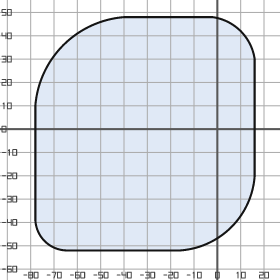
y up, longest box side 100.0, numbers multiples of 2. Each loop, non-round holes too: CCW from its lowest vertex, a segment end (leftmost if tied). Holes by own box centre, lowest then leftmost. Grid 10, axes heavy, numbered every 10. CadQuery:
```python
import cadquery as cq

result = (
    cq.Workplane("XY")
    .moveTo(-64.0, -52.0)
    .lineTo(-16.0, -52.0)
    .threePointArc((6.0, -42.0), (16.0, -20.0))
    .lineTo(16.0, 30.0)
    .threePointArc((10.0, 42.0), (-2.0, 48.0))
    .lineTo(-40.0, 48.0)
    .threePointArc((-66.0, 36.0), (-78.0, 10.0))
    .lineTo(-78.0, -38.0)
    .threePointArc((-74.0, -48.0), (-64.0, -52.0))
    .close()
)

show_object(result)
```